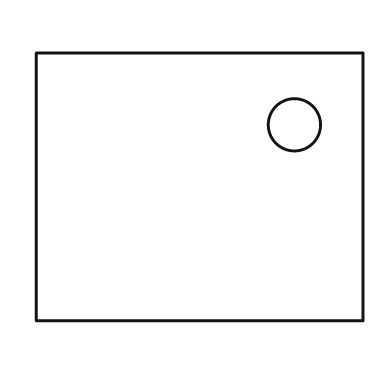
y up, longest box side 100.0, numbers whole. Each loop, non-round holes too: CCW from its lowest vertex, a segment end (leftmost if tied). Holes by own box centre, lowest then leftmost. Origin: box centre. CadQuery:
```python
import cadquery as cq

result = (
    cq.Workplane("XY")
    .moveTo(-50.0, -41.0)
    .lineTo(50.0, -41.0)
    .lineTo(50.0, 41.0)
    .lineTo(-50.0, 41.0)
    .close()
    .moveTo(29.0, 19.0)
    .circle(8.0)
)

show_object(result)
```